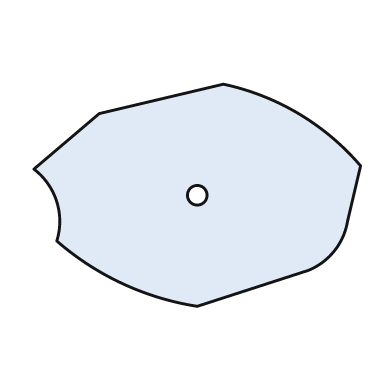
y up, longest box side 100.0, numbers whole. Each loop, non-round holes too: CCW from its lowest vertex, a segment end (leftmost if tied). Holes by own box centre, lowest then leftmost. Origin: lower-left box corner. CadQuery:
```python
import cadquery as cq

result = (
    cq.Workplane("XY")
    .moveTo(50.0, 0.0)
    .lineTo(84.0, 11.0)
    .threePointArc((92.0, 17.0), (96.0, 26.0))
    .lineTo(100.0, 43.0)
    .threePointArc((81.0, 59.0), (58.0, 68.0))
    .lineTo(20.0, 59.0)
    .lineTo(0.0, 42.0)
    .threePointArc((7.0, 32.0), (7.0, 20.0))
    .threePointArc((27.0, 7.0), (50.0, 0.0))
    .close()
    .moveTo(50.0, 34.0)
    .circle(3.0)
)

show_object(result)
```